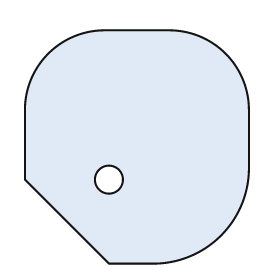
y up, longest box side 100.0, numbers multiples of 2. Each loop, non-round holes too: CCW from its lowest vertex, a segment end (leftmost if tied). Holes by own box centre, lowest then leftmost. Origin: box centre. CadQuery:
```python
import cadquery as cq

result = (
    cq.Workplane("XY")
    .moveTo(-12.0, -50.0)
    .lineTo(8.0, -50.0)
    .threePointArc((36.0, -38.0), (48.0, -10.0))
    .lineTo(48.0, 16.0)
    .threePointArc((38.0, 40.0), (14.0, 50.0))
    .lineTo(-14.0, 50.0)
    .threePointArc((-38.0, 40.0), (-48.0, 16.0))
    .lineTo(-48.0, -14.0)
    .close()
    .moveTo(-12.0, -14.0)
    .circle(6.0)
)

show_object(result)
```